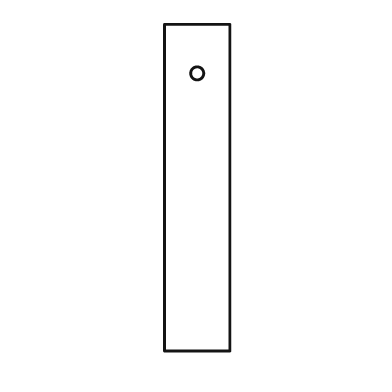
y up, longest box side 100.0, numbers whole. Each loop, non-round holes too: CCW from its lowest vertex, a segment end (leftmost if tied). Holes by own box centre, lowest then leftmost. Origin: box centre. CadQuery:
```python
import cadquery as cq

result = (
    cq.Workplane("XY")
    .moveTo(-10.0, -50.0)
    .lineTo(10.0, -50.0)
    .lineTo(10.0, 50.0)
    .lineTo(-10.0, 50.0)
    .close()
    .moveTo(0.0, 35.0)
    .circle(2.0)
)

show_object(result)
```